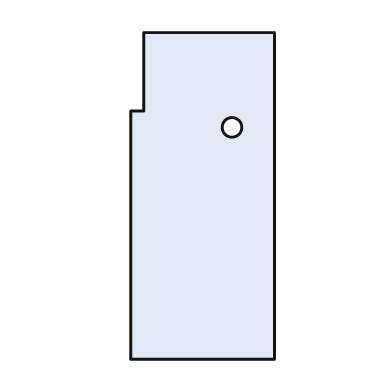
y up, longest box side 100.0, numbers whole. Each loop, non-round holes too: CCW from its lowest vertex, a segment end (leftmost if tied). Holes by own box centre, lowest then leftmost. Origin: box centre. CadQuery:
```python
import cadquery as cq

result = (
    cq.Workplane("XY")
    .moveTo(-22.0, -50.0)
    .lineTo(22.0, -50.0)
    .lineTo(22.0, 50.0)
    .lineTo(-18.0, 50.0)
    .lineTo(-18.0, 26.0)
    .lineTo(-22.0, 26.0)
    .close()
    .moveTo(9.0, 21.0)
    .circle(3.0)
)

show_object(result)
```